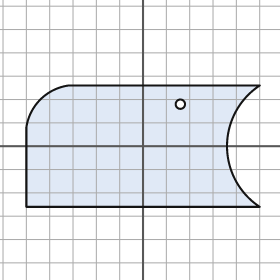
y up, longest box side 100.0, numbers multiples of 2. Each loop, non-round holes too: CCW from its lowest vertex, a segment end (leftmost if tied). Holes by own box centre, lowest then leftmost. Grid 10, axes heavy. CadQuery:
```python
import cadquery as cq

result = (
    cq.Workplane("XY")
    .moveTo(-50.0, -26.0)
    .lineTo(50.0, -26.0)
    .threePointArc((36.0, 0.0), (50.0, 26.0))
    .lineTo(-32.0, 26.0)
    .threePointArc((-44.0, 20.0), (-50.0, 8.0))
    .close()
    .moveTo(16.0, 18.0)
    .circle(2.0)
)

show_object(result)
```